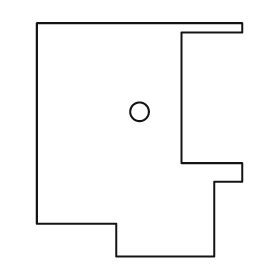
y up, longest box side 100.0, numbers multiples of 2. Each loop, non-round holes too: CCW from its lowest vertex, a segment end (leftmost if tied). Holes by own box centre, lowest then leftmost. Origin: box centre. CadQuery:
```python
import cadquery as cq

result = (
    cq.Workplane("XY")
    .moveTo(-10.0, -50.0)
    .lineTo(32.0, -50.0)
    .lineTo(32.0, -18.0)
    .lineTo(44.0, -18.0)
    .lineTo(44.0, -10.0)
    .lineTo(18.0, -10.0)
    .lineTo(18.0, 46.0)
    .lineTo(44.0, 46.0)
    .lineTo(44.0, 50.0)
    .lineTo(-44.0, 50.0)
    .lineTo(-44.0, -36.0)
    .lineTo(-10.0, -36.0)
    .close()
    .moveTo(0.0, 12.0)
    .circle(4.0)
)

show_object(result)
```